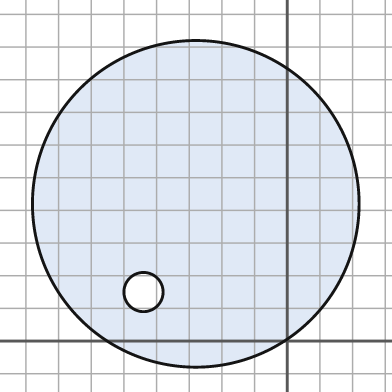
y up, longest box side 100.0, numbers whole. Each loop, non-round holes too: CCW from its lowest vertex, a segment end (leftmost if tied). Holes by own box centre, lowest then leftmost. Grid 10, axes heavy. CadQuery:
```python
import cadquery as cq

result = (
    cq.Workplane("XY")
    .moveTo(-28.0, 42.0)
    .circle(50.0)
    .moveTo(-44.0, 15.0)
    .circle(6.0)
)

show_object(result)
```